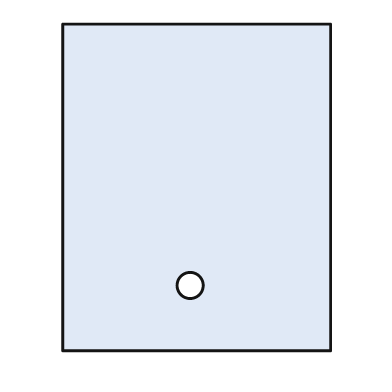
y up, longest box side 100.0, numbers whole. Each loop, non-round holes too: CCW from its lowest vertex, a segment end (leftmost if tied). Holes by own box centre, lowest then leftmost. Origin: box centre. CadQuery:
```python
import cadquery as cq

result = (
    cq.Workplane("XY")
    .moveTo(-41.0, -50.0)
    .lineTo(41.0, -50.0)
    .lineTo(41.0, 50.0)
    .lineTo(-41.0, 50.0)
    .close()
    .moveTo(-2.0, -30.0)
    .circle(4.0)
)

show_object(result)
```